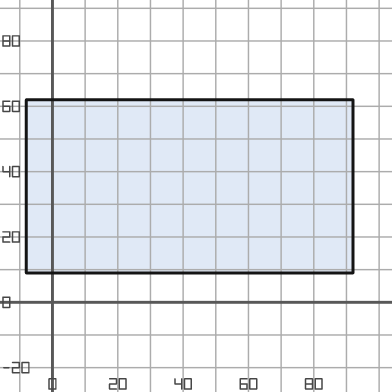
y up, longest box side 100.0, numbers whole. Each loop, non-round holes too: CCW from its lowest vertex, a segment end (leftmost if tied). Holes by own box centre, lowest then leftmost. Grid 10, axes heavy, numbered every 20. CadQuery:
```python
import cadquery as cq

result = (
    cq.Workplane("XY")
    .moveTo(-8.0, 9.0)
    .lineTo(92.0, 9.0)
    .lineTo(92.0, 62.0)
    .lineTo(-8.0, 62.0)
    .close()
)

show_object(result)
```